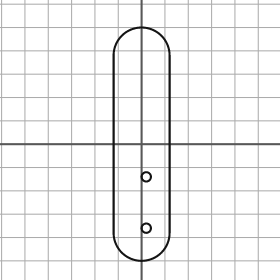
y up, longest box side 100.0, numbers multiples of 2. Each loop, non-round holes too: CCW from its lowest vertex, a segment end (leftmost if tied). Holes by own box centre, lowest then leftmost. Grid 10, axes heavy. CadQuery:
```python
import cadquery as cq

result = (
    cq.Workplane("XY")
    .moveTo(-12.0, -38.0)
    .threePointArc((0.0, -50.0), (12.0, -38.0))
    .lineTo(12.0, 38.0)
    .threePointArc((0.0, 50.0), (-12.0, 38.0))
    .close()
    .moveTo(2.0, -36.0)
    .circle(2.0)
    .moveTo(2.0, -14.0)
    .circle(2.0)
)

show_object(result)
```